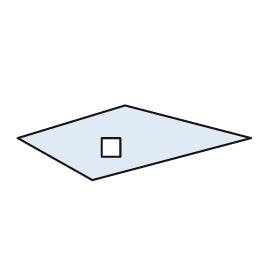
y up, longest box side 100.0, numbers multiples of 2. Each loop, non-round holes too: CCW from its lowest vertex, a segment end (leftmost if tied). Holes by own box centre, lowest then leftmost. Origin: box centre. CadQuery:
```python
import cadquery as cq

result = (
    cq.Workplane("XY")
    .moveTo(-18.0, -16.0)
    .lineTo(50.0, 2.0)
    .lineTo(-4.0, 16.0)
    .lineTo(-50.0, 2.0)
    .close()
    .moveTo(-14.0, -6.0)
    .lineTo(-6.0, -6.0)
    .lineTo(-6.0, 2.0)
    .lineTo(-14.0, 2.0)
    .close()
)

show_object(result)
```